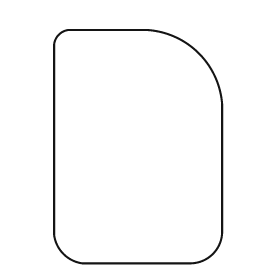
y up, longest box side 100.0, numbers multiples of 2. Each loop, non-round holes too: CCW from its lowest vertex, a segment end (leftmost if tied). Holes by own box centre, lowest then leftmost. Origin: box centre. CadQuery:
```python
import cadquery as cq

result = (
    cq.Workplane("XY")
    .moveTo(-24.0, -50.0)
    .lineTo(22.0, -50.0)
    .threePointArc((32.0, -46.0), (36.0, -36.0))
    .lineTo(36.0, 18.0)
    .threePointArc((26.0, 40.0), (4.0, 50.0))
    .lineTo(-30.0, 50.0)
    .threePointArc((-34.0, 48.0), (-36.0, 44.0))
    .lineTo(-36.0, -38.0)
    .threePointArc((-32.0, -46.0), (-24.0, -50.0))
    .close()
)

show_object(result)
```